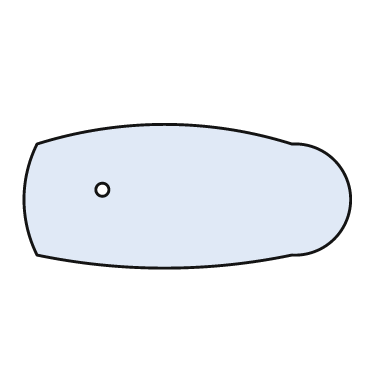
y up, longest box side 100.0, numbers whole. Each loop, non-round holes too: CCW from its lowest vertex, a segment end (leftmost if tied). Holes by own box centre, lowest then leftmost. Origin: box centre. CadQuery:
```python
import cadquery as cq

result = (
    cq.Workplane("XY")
    .moveTo(-46.0, -18.0)
    .threePointArc((-7.0, -22.0), (32.0, -18.0))
    .threePointArc((50.0, -1.0), (32.0, 16.0))
    .threePointArc((-7.0, 22.0), (-46.0, 16.0))
    .threePointArc((-50.0, -1.0), (-46.0, -18.0))
    .close()
    .moveTo(-26.0, 2.0)
    .circle(2.0)
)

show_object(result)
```